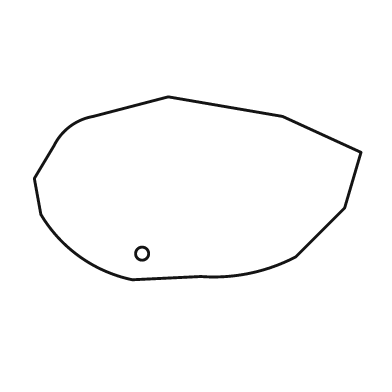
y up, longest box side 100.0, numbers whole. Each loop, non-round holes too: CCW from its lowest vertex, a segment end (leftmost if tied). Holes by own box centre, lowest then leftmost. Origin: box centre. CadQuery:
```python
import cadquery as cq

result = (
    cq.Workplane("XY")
    .moveTo(-20.0, -28.0)
    .lineTo(1.0, -27.0)
    .threePointArc((16.0, -26.0), (30.0, -21.0))
    .lineTo(45.0, -6.0)
    .lineTo(50.0, 11.0)
    .lineTo(26.0, 22.0)
    .lineTo(-9.0, 28.0)
    .lineTo(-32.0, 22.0)
    .threePointArc((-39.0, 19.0), (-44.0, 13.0))
    .lineTo(-50.0, 3.0)
    .lineTo(-48.0, -8.0)
    .threePointArc((-36.0, -21.0), (-20.0, -28.0))
    .close()
    .moveTo(-17.0, -20.0)
    .circle(2.0)
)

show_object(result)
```